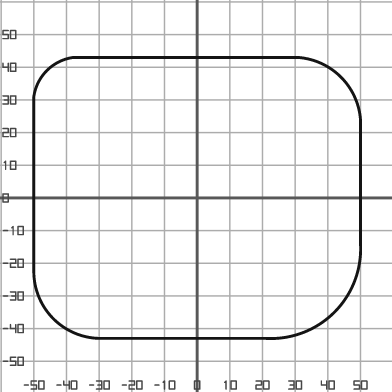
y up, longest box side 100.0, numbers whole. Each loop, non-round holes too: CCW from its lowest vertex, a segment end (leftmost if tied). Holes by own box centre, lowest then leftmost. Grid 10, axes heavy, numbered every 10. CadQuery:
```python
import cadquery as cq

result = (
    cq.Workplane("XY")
    .moveTo(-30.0, -43.0)
    .lineTo(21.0, -43.0)
    .threePointArc((42.0, -35.0), (50.0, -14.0))
    .lineTo(50.0, 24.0)
    .threePointArc((44.0, 37.0), (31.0, 43.0))
    .lineTo(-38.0, 43.0)
    .threePointArc((-46.0, 39.0), (-50.0, 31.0))
    .lineTo(-50.0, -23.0)
    .threePointArc((-44.0, -37.0), (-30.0, -43.0))
    .close()
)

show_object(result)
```